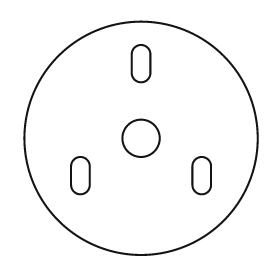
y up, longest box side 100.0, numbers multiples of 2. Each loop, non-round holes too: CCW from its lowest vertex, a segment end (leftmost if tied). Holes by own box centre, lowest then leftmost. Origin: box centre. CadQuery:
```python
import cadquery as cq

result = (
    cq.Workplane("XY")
    .moveTo(0.0, 0.0)
    .circle(50.0)
    .moveTo(-30.0, -20.0)
    .threePointArc((-26.0, -24.0), (-22.0, -20.0))
    .lineTo(-22.0, -12.0)
    .threePointArc((-26.0, -8.0), (-30.0, -12.0))
    .close()
    .moveTo(22.0, -20.0)
    .threePointArc((26.0, -24.0), (30.0, -20.0))
    .lineTo(30.0, -12.0)
    .threePointArc((26.0, -8.0), (22.0, -12.0))
    .close()
    .moveTo(0.0, 0.0)
    .circle(8.0)
    .moveTo(-4.0, 28.0)
    .threePointArc((0.0, 24.0), (4.0, 28.0))
    .lineTo(4.0, 36.0)
    .threePointArc((0.0, 40.0), (-4.0, 36.0))
    .close()
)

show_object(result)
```